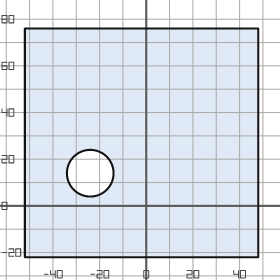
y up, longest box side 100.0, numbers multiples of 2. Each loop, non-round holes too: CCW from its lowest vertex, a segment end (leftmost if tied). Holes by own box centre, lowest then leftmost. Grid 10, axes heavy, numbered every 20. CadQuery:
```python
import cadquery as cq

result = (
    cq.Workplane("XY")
    .moveTo(-52.0, -22.0)
    .lineTo(48.0, -22.0)
    .lineTo(48.0, 76.0)
    .lineTo(-52.0, 76.0)
    .close()
    .moveTo(-24.0, 14.0)
    .circle(10.0)
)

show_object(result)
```